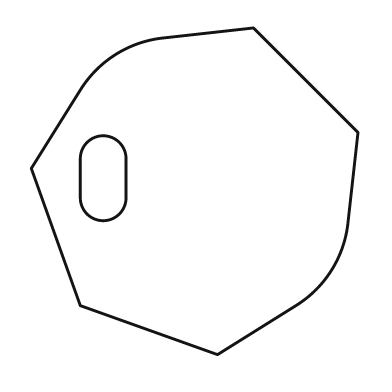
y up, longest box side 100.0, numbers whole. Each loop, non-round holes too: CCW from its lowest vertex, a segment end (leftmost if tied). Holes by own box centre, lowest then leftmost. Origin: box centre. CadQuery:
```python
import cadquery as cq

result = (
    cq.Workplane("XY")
    .moveTo(7.0, -50.0)
    .lineTo(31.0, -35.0)
    .threePointArc((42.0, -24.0), (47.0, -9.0))
    .lineTo(50.0, 18.0)
    .lineTo(18.0, 50.0)
    .lineTo(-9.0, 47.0)
    .threePointArc((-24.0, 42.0), (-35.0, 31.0))
    .lineTo(-50.0, 7.0)
    .lineTo(-35.0, -35.0)
    .close()
    .moveTo(-35.0, -2.0)
    .threePointArc((-28.0, -9.0), (-21.0, -2.0))
    .lineTo(-21.0, 10.0)
    .threePointArc((-28.0, 17.0), (-35.0, 10.0))
    .close()
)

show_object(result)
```